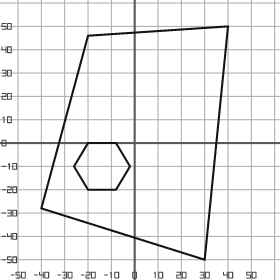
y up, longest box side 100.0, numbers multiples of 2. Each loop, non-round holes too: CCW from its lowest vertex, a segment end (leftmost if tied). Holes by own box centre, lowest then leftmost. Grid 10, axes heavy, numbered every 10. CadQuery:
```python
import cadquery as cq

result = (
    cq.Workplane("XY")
    .moveTo(30.0, -50.0)
    .lineTo(40.0, 50.0)
    .lineTo(-20.0, 46.0)
    .lineTo(-40.0, -28.0)
    .close()
    .moveTo(-20.0, -20.0)
    .lineTo(-8.0, -20.0)
    .lineTo(-2.0, -10.0)
    .lineTo(-8.0, 0.0)
    .lineTo(-20.0, 0.0)
    .lineTo(-26.0, -10.0)
    .close()
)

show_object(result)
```